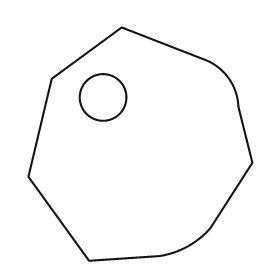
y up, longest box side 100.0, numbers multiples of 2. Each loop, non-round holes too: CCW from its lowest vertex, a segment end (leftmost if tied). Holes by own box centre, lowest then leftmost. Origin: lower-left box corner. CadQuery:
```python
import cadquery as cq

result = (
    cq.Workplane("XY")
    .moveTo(26.0, 0.0)
    .lineTo(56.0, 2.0)
    .threePointArc((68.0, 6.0), (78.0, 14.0))
    .lineTo(96.0, 42.0)
    .lineTo(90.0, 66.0)
    .threePointArc((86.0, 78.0), (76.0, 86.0))
    .lineTo(40.0, 100.0)
    .lineTo(10.0, 78.0)
    .lineTo(0.0, 36.0)
    .close()
    .moveTo(32.0, 70.0)
    .circle(10.0)
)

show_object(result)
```